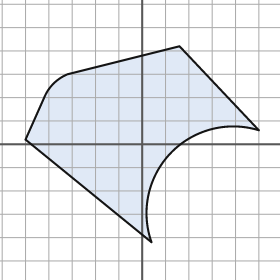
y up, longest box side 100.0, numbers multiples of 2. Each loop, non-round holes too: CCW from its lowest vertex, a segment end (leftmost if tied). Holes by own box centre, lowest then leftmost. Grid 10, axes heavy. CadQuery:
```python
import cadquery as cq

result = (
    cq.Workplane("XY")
    .moveTo(4.0, -42.0)
    .threePointArc((12.0, -4.0), (50.0, 6.0))
    .lineTo(16.0, 42.0)
    .lineTo(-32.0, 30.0)
    .threePointArc((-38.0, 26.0), (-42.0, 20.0))
    .lineTo(-50.0, 2.0)
    .close()
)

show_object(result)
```